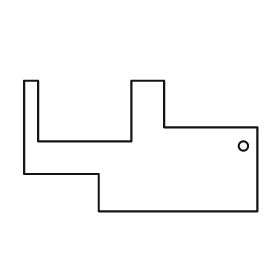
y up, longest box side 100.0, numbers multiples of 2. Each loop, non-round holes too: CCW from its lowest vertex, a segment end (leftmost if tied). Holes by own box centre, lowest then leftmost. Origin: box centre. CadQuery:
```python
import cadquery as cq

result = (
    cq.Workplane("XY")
    .moveTo(-18.0, -28.0)
    .lineTo(50.0, -28.0)
    .lineTo(50.0, 8.0)
    .lineTo(10.0, 8.0)
    .lineTo(10.0, 28.0)
    .lineTo(-4.0, 28.0)
    .lineTo(-4.0, 2.0)
    .lineTo(-44.0, 2.0)
    .lineTo(-44.0, 28.0)
    .lineTo(-50.0, 28.0)
    .lineTo(-50.0, -12.0)
    .lineTo(-18.0, -12.0)
    .close()
    .moveTo(44.0, 0.0)
    .circle(2.0)
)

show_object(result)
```